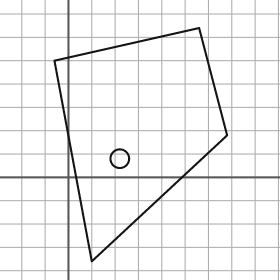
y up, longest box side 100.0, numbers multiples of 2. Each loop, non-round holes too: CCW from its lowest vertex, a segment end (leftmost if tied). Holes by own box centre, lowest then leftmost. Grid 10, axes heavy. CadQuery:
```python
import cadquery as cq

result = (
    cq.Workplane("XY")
    .moveTo(10.0, -36.0)
    .lineTo(68.0, 18.0)
    .lineTo(56.0, 64.0)
    .lineTo(-6.0, 50.0)
    .close()
    .moveTo(22.0, 8.0)
    .circle(4.0)
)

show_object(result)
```